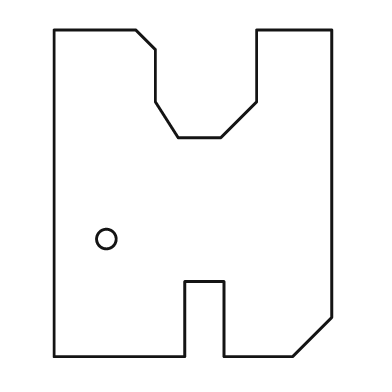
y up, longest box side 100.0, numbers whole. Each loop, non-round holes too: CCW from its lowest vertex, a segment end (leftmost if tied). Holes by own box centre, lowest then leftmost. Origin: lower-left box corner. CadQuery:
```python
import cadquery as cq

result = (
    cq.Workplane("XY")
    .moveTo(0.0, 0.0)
    .lineTo(40.0, 0.0)
    .lineTo(40.0, 23.0)
    .lineTo(52.0, 23.0)
    .lineTo(52.0, 0.0)
    .lineTo(73.0, 0.0)
    .lineTo(85.0, 12.0)
    .lineTo(85.0, 100.0)
    .lineTo(62.0, 100.0)
    .lineTo(62.0, 78.0)
    .lineTo(51.0, 67.0)
    .lineTo(38.0, 67.0)
    .lineTo(31.0, 78.0)
    .lineTo(31.0, 94.0)
    .lineTo(25.0, 100.0)
    .lineTo(0.0, 100.0)
    .close()
    .moveTo(16.0, 36.0)
    .circle(3.0)
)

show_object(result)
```